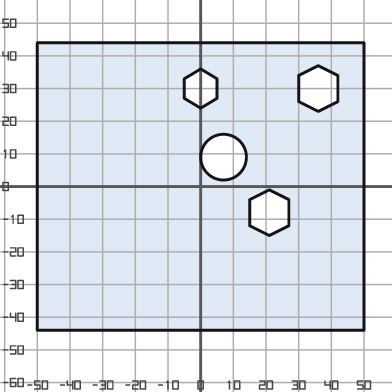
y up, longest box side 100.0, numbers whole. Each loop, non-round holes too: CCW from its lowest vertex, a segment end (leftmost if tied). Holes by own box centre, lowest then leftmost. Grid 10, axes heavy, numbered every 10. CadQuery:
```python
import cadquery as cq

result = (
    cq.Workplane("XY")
    .moveTo(-50.0, -44.0)
    .lineTo(50.0, -44.0)
    .lineTo(50.0, 44.0)
    .lineTo(-50.0, 44.0)
    .close()
    .moveTo(21.0, -15.0)
    .lineTo(27.0, -12.0)
    .lineTo(27.0, -4.0)
    .lineTo(21.0, -1.0)
    .lineTo(15.0, -4.0)
    .lineTo(15.0, -12.0)
    .close()
    .moveTo(7.0, 9.0)
    .circle(7.0)
    .moveTo(0.0, 24.0)
    .lineTo(5.0, 27.0)
    .lineTo(5.0, 33.0)
    .lineTo(0.0, 36.0)
    .lineTo(-5.0, 33.0)
    .lineTo(-5.0, 27.0)
    .close()
    .moveTo(36.0, 23.0)
    .lineTo(42.0, 26.0)
    .lineTo(42.0, 34.0)
    .lineTo(36.0, 37.0)
    .lineTo(30.0, 34.0)
    .lineTo(30.0, 26.0)
    .close()
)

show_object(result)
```